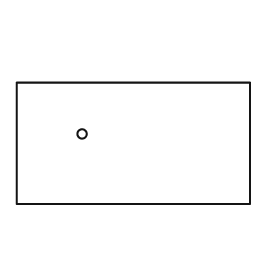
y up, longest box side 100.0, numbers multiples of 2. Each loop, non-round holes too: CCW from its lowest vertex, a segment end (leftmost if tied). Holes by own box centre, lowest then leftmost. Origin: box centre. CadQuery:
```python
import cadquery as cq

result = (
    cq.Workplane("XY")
    .moveTo(-50.0, -26.0)
    .lineTo(50.0, -26.0)
    .lineTo(50.0, 26.0)
    .lineTo(-50.0, 26.0)
    .close()
    .moveTo(-22.0, 4.0)
    .circle(2.0)
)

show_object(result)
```